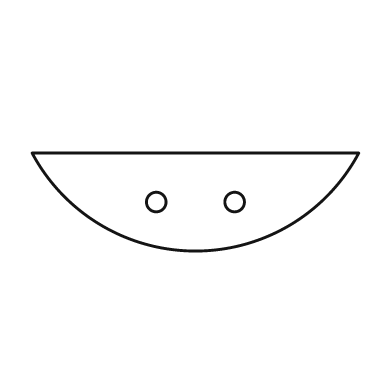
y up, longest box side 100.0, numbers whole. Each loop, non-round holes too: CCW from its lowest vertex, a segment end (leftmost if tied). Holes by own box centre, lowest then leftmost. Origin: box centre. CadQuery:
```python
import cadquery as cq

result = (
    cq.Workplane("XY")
    .moveTo(-50.0, 15.0)
    .threePointArc((0.0, -15.0), (50.0, 15.0))
    .close()
    .moveTo(-12.0, 0.0)
    .circle(3.0)
    .moveTo(12.0, 0.0)
    .circle(3.0)
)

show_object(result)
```